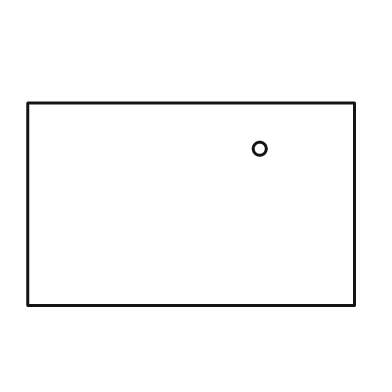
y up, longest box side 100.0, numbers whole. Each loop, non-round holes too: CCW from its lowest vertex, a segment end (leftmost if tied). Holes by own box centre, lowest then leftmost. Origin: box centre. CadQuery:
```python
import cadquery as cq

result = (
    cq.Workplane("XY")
    .moveTo(-50.0, -31.0)
    .lineTo(50.0, -31.0)
    .lineTo(50.0, 31.0)
    .lineTo(-50.0, 31.0)
    .close()
    .moveTo(21.0, 17.0)
    .circle(2.0)
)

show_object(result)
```